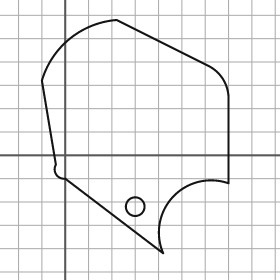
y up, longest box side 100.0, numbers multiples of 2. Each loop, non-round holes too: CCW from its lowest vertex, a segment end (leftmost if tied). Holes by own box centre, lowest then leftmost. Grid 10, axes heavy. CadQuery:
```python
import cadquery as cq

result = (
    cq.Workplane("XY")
    .moveTo(42.0, -42.0)
    .threePointArc((46.0, -18.0), (70.0, -12.0))
    .lineTo(70.0, 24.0)
    .threePointArc((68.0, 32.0), (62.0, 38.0))
    .lineTo(22.0, 58.0)
    .threePointArc((2.0, 50.0), (-10.0, 32.0))
    .lineTo(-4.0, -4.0)
    .threePointArc((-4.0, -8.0), (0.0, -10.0))
    .close()
    .moveTo(30.0, -22.0)
    .circle(4.0)
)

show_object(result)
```